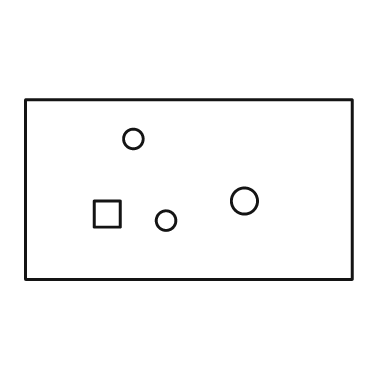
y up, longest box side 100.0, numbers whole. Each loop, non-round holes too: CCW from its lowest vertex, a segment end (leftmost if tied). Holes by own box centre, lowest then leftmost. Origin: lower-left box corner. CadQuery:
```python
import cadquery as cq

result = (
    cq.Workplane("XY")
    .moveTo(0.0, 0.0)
    .lineTo(100.0, 0.0)
    .lineTo(100.0, 55.0)
    .lineTo(0.0, 55.0)
    .close()
    .moveTo(43.0, 18.0)
    .circle(3.0)
    .moveTo(21.0, 16.0)
    .lineTo(29.0, 16.0)
    .lineTo(29.0, 24.0)
    .lineTo(21.0, 24.0)
    .close()
    .moveTo(67.0, 24.0)
    .circle(4.0)
    .moveTo(33.0, 43.0)
    .circle(3.0)
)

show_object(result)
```